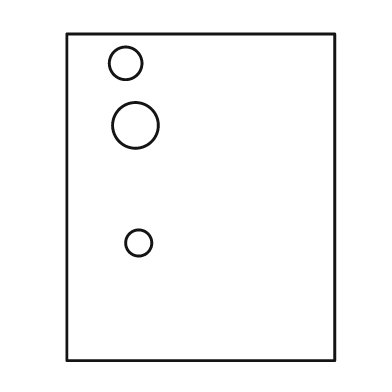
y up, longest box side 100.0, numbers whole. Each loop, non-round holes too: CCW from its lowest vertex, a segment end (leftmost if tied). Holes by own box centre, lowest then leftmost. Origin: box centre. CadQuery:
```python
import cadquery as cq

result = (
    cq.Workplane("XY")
    .moveTo(-41.0, -50.0)
    .lineTo(41.0, -50.0)
    .lineTo(41.0, 50.0)
    .lineTo(-41.0, 50.0)
    .close()
    .moveTo(-19.0, -14.0)
    .circle(4.0)
    .moveTo(-20.0, 22.0)
    .circle(7.0)
    .moveTo(-23.0, 41.0)
    .circle(5.0)
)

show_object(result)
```